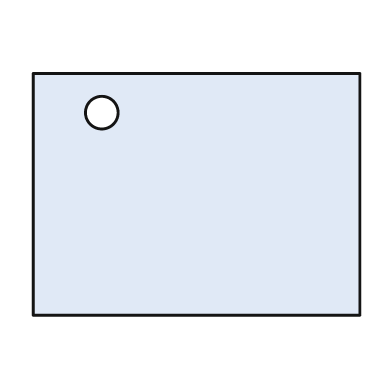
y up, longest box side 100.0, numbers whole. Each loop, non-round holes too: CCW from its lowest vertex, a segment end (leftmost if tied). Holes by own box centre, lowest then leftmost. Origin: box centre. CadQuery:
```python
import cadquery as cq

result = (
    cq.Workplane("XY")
    .moveTo(-50.0, -37.0)
    .lineTo(50.0, -37.0)
    .lineTo(50.0, 37.0)
    .lineTo(-50.0, 37.0)
    .close()
    .moveTo(-29.0, 25.0)
    .circle(5.0)
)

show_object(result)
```